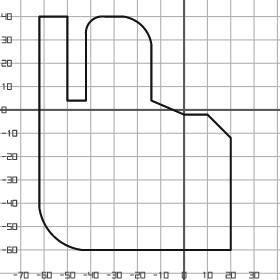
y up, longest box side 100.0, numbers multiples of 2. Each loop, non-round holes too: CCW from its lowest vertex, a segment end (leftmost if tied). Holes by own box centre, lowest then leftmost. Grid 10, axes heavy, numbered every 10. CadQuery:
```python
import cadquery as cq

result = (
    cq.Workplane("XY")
    .moveTo(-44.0, -60.0)
    .lineTo(20.0, -60.0)
    .lineTo(20.0, -12.0)
    .lineTo(10.0, -2.0)
    .lineTo(0.0, -2.0)
    .lineTo(-14.0, 4.0)
    .lineTo(-14.0, 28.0)
    .threePointArc((-18.0, 36.0), (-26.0, 40.0))
    .lineTo(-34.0, 40.0)
    .threePointArc((-40.0, 38.0), (-42.0, 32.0))
    .lineTo(-42.0, 4.0)
    .lineTo(-50.0, 4.0)
    .lineTo(-50.0, 40.0)
    .lineTo(-62.0, 40.0)
    .lineTo(-62.0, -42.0)
    .threePointArc((-56.0, -54.0), (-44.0, -60.0))
    .close()
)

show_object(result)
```